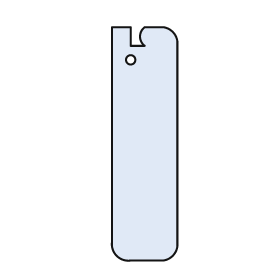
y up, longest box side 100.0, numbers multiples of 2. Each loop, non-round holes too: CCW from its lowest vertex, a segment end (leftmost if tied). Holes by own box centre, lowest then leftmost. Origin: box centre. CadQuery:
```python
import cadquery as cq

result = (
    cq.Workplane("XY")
    .moveTo(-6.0, -50.0)
    .lineTo(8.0, -50.0)
    .threePointArc((12.0, -48.0), (14.0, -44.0))
    .lineTo(14.0, 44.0)
    .threePointArc((12.0, 48.0), (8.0, 50.0))
    .lineTo(0.0, 50.0)
    .threePointArc((-2.0, 46.0), (0.0, 42.0))
    .lineTo(-6.0, 42.0)
    .lineTo(-6.0, 50.0)
    .lineTo(-14.0, 50.0)
    .lineTo(-14.0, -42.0)
    .threePointArc((-12.0, -48.0), (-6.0, -50.0))
    .close()
    .moveTo(-6.0, 36.0)
    .circle(2.0)
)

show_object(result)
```